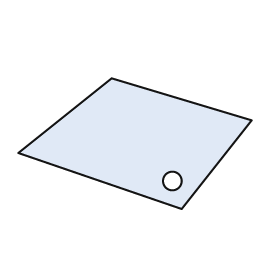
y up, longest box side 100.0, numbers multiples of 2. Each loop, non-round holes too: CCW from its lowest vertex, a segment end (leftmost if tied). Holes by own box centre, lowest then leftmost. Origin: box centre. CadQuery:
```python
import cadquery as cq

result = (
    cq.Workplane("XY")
    .moveTo(20.0, -28.0)
    .lineTo(50.0, 10.0)
    .lineTo(-10.0, 28.0)
    .lineTo(-50.0, -4.0)
    .close()
    .moveTo(16.0, -16.0)
    .circle(4.0)
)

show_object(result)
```